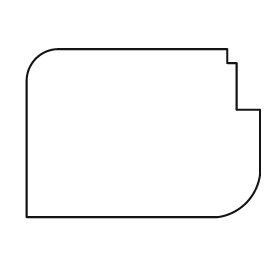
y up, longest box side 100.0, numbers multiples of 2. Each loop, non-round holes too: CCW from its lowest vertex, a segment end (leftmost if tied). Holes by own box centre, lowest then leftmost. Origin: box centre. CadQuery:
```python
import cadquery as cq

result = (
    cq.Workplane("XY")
    .moveTo(-50.0, -36.0)
    .lineTo(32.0, -36.0)
    .threePointArc((44.0, -30.0), (50.0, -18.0))
    .lineTo(50.0, 10.0)
    .lineTo(40.0, 10.0)
    .lineTo(40.0, 30.0)
    .lineTo(36.0, 30.0)
    .lineTo(36.0, 36.0)
    .lineTo(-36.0, 36.0)
    .threePointArc((-46.0, 32.0), (-50.0, 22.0))
    .close()
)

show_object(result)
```